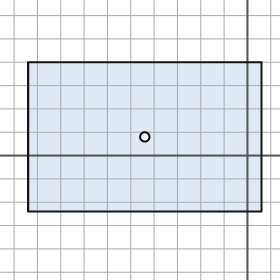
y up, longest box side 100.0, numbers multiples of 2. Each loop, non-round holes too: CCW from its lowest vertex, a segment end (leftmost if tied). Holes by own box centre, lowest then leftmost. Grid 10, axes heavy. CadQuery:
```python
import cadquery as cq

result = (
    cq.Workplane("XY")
    .moveTo(-94.0, -24.0)
    .lineTo(6.0, -24.0)
    .lineTo(6.0, 40.0)
    .lineTo(-94.0, 40.0)
    .close()
    .moveTo(-44.0, 8.0)
    .circle(2.0)
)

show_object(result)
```